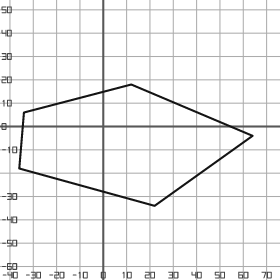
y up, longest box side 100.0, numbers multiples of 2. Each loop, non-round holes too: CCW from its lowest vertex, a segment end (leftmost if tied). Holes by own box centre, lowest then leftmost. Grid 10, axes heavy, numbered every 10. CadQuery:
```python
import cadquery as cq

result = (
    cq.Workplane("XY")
    .moveTo(22.0, -34.0)
    .lineTo(64.0, -4.0)
    .lineTo(12.0, 18.0)
    .lineTo(-34.0, 6.0)
    .lineTo(-36.0, -18.0)
    .close()
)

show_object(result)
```